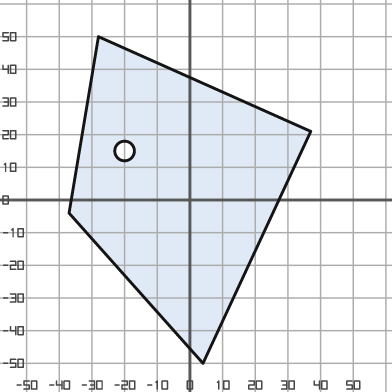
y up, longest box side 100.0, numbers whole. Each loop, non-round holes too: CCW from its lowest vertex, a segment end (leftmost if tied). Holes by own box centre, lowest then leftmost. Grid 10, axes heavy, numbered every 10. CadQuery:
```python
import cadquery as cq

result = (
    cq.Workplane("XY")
    .moveTo(4.0, -50.0)
    .lineTo(37.0, 21.0)
    .lineTo(-28.0, 50.0)
    .lineTo(-37.0, -4.0)
    .close()
    .moveTo(-20.0, 15.0)
    .circle(3.0)
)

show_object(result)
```